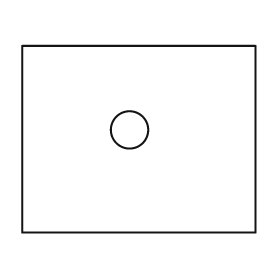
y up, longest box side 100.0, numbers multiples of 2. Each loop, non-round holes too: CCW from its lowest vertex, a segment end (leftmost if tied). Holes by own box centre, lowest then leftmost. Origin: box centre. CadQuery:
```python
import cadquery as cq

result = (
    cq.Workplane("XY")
    .moveTo(-50.0, -40.0)
    .lineTo(50.0, -40.0)
    .lineTo(50.0, 40.0)
    .lineTo(-50.0, 40.0)
    .close()
    .moveTo(-4.0, 4.0)
    .circle(8.0)
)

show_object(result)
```